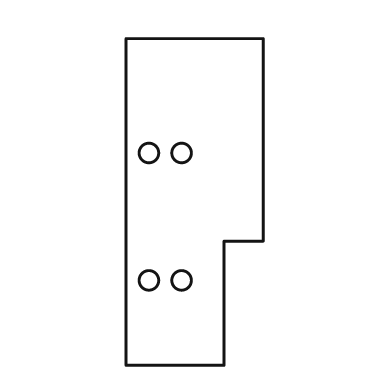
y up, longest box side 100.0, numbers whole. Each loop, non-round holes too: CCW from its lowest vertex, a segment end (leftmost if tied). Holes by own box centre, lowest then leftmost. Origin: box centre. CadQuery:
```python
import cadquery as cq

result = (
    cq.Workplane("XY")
    .moveTo(-21.0, -50.0)
    .lineTo(9.0, -50.0)
    .lineTo(9.0, -12.0)
    .lineTo(21.0, -12.0)
    .lineTo(21.0, 50.0)
    .lineTo(-21.0, 50.0)
    .close()
    .moveTo(-14.0, -24.0)
    .circle(3.0)
    .moveTo(-4.0, -24.0)
    .circle(3.0)
    .moveTo(-14.0, 15.0)
    .circle(3.0)
    .moveTo(-4.0, 15.0)
    .circle(3.0)
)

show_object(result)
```